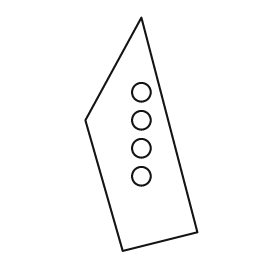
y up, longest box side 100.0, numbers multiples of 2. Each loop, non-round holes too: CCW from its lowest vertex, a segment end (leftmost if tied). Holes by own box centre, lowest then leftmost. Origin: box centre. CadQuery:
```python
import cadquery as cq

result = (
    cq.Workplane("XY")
    .moveTo(-8.0, -50.0)
    .lineTo(24.0, -42.0)
    .lineTo(0.0, 50.0)
    .lineTo(-24.0, 6.0)
    .close()
    .moveTo(0.0, -18.0)
    .circle(4.0)
    .moveTo(0.0, -6.0)
    .circle(4.0)
    .moveTo(0.0, 6.0)
    .circle(4.0)
    .moveTo(0.0, 18.0)
    .circle(4.0)
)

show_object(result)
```